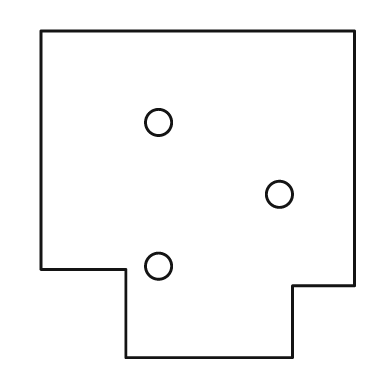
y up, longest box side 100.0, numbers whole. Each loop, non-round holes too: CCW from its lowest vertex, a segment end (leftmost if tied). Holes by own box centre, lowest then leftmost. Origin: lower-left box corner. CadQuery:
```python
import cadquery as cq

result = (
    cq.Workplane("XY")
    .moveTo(26.0, 0.0)
    .lineTo(77.0, 0.0)
    .lineTo(77.0, 22.0)
    .lineTo(96.0, 22.0)
    .lineTo(96.0, 100.0)
    .lineTo(0.0, 100.0)
    .lineTo(0.0, 27.0)
    .lineTo(26.0, 27.0)
    .close()
    .moveTo(36.0, 28.0)
    .circle(4.0)
    .moveTo(73.0, 50.0)
    .circle(4.0)
    .moveTo(36.0, 72.0)
    .circle(4.0)
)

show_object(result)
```